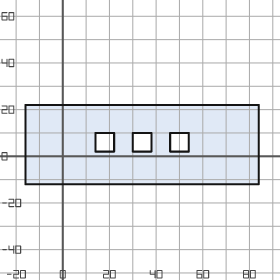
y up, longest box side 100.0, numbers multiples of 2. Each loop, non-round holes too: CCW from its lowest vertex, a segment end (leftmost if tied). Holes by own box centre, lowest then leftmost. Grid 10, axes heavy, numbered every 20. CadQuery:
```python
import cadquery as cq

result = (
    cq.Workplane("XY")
    .moveTo(-16.0, -12.0)
    .lineTo(84.0, -12.0)
    .lineTo(84.0, 22.0)
    .lineTo(-16.0, 22.0)
    .close()
    .moveTo(14.0, 2.0)
    .lineTo(22.0, 2.0)
    .lineTo(22.0, 10.0)
    .lineTo(14.0, 10.0)
    .close()
    .moveTo(30.0, 2.0)
    .lineTo(38.0, 2.0)
    .lineTo(38.0, 10.0)
    .lineTo(30.0, 10.0)
    .close()
    .moveTo(46.0, 2.0)
    .lineTo(54.0, 2.0)
    .lineTo(54.0, 10.0)
    .lineTo(46.0, 10.0)
    .close()
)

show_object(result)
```